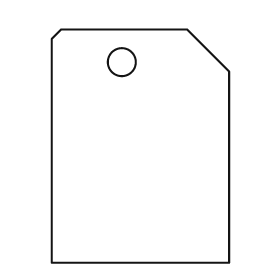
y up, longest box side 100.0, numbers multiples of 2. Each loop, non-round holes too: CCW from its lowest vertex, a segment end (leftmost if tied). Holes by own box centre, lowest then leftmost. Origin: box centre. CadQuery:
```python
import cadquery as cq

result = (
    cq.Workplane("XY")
    .moveTo(-38.0, -50.0)
    .lineTo(38.0, -50.0)
    .lineTo(38.0, 32.0)
    .lineTo(20.0, 50.0)
    .lineTo(-34.0, 50.0)
    .lineTo(-38.0, 46.0)
    .close()
    .moveTo(-8.0, 36.0)
    .circle(6.0)
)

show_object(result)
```